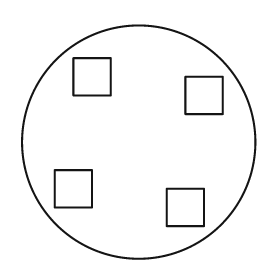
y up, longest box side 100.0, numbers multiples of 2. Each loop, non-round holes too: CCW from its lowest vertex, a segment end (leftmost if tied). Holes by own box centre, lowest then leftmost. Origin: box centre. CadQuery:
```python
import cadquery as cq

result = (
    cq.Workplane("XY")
    .moveTo(0.0, 0.0)
    .circle(50.0)
    .moveTo(12.0, -36.0)
    .lineTo(28.0, -36.0)
    .lineTo(28.0, -20.0)
    .lineTo(12.0, -20.0)
    .close()
    .moveTo(-36.0, -28.0)
    .lineTo(-20.0, -28.0)
    .lineTo(-20.0, -12.0)
    .lineTo(-36.0, -12.0)
    .close()
    .moveTo(20.0, 12.0)
    .lineTo(36.0, 12.0)
    .lineTo(36.0, 28.0)
    .lineTo(20.0, 28.0)
    .close()
    .moveTo(-28.0, 20.0)
    .lineTo(-12.0, 20.0)
    .lineTo(-12.0, 36.0)
    .lineTo(-28.0, 36.0)
    .close()
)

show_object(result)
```